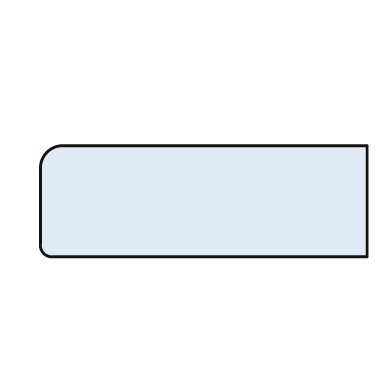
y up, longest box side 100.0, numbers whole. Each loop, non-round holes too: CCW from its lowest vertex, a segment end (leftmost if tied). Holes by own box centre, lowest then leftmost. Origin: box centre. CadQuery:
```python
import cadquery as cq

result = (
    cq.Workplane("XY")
    .moveTo(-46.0, -17.0)
    .lineTo(50.0, -17.0)
    .lineTo(50.0, 17.0)
    .lineTo(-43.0, 17.0)
    .threePointArc((-48.0, 15.0), (-50.0, 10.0))
    .lineTo(-50.0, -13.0)
    .threePointArc((-49.0, -16.0), (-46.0, -17.0))
    .close()
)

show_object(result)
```